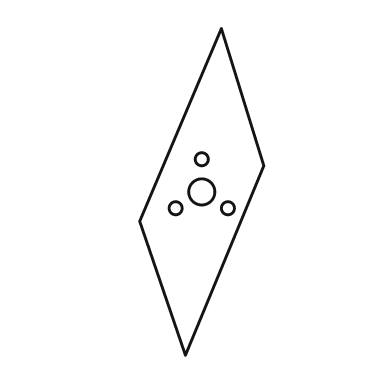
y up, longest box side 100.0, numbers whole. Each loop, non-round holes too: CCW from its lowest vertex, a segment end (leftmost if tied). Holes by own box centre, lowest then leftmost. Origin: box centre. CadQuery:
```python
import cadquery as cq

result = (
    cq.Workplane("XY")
    .moveTo(-5.0, -50.0)
    .lineTo(19.0, 8.0)
    .lineTo(6.0, 50.0)
    .lineTo(-19.0, -9.0)
    .close()
    .moveTo(-8.0, -5.0)
    .circle(2.0)
    .moveTo(8.0, -5.0)
    .circle(2.0)
    .moveTo(0.0, 0.0)
    .circle(4.0)
    .moveTo(0.0, 10.0)
    .circle(2.0)
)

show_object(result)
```